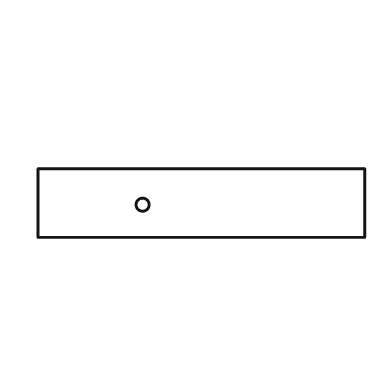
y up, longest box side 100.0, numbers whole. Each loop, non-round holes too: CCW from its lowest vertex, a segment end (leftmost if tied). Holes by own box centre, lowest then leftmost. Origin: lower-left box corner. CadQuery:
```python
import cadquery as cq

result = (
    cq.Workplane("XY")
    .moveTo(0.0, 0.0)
    .lineTo(100.0, 0.0)
    .lineTo(100.0, 21.0)
    .lineTo(0.0, 21.0)
    .close()
    .moveTo(32.0, 10.0)
    .circle(2.0)
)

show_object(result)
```